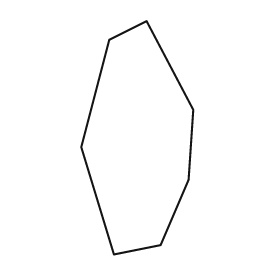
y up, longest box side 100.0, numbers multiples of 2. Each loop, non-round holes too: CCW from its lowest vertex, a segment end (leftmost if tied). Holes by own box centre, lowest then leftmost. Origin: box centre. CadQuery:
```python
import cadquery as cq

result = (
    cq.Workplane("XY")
    .moveTo(-10.0, -50.0)
    .lineTo(10.0, -46.0)
    .lineTo(22.0, -18.0)
    .lineTo(24.0, 12.0)
    .lineTo(4.0, 50.0)
    .lineTo(-12.0, 42.0)
    .lineTo(-24.0, -4.0)
    .close()
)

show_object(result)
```